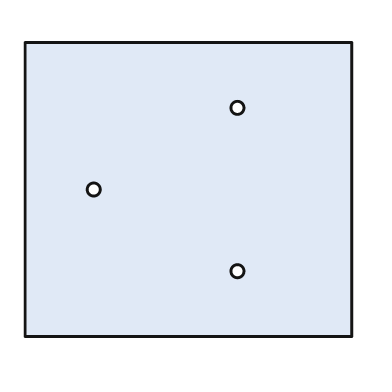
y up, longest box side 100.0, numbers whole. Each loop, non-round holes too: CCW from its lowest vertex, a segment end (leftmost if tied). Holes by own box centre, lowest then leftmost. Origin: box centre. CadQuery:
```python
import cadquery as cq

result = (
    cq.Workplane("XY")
    .moveTo(-50.0, -45.0)
    .lineTo(50.0, -45.0)
    .lineTo(50.0, 45.0)
    .lineTo(-50.0, 45.0)
    .close()
    .moveTo(15.0, -25.0)
    .circle(2.0)
    .moveTo(-29.0, 0.0)
    .circle(2.0)
    .moveTo(15.0, 25.0)
    .circle(2.0)
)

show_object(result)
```